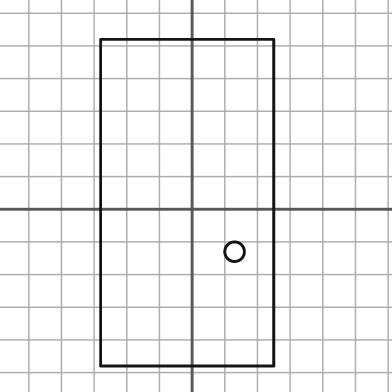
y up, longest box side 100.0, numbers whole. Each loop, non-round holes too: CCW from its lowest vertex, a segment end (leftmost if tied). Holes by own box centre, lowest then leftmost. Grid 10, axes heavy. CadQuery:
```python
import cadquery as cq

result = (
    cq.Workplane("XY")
    .moveTo(-28.0, -48.0)
    .lineTo(25.0, -48.0)
    .lineTo(25.0, 52.0)
    .lineTo(-28.0, 52.0)
    .close()
    .moveTo(13.0, -13.0)
    .circle(3.0)
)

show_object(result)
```